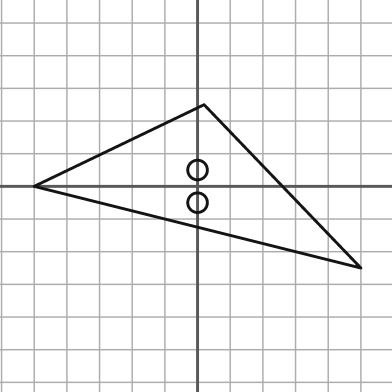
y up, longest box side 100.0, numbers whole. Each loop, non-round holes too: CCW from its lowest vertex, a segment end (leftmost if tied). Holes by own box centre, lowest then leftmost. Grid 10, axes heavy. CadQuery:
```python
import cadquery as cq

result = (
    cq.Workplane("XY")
    .moveTo(50.0, -25.0)
    .lineTo(2.0, 25.0)
    .lineTo(-50.0, 0.0)
    .close()
    .moveTo(0.0, -5.0)
    .circle(3.0)
    .moveTo(0.0, 5.0)
    .circle(3.0)
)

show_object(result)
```